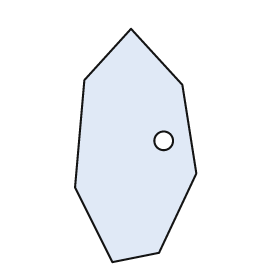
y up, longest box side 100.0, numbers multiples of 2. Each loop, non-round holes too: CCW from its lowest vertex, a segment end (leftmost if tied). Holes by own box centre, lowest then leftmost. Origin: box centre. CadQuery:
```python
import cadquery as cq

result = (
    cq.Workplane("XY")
    .moveTo(-10.0, -50.0)
    .lineTo(10.0, -46.0)
    .lineTo(26.0, -12.0)
    .lineTo(20.0, 26.0)
    .lineTo(-2.0, 50.0)
    .lineTo(-22.0, 28.0)
    .lineTo(-26.0, -18.0)
    .close()
    .moveTo(12.0, 2.0)
    .circle(4.0)
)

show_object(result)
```